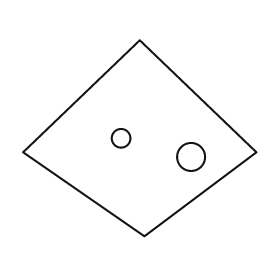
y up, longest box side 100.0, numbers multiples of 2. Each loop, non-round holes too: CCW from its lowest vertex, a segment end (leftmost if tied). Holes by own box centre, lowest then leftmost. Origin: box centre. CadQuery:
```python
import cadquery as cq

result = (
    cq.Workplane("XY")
    .moveTo(2.0, -42.0)
    .lineTo(50.0, -6.0)
    .lineTo(0.0, 42.0)
    .lineTo(-50.0, -6.0)
    .close()
    .moveTo(22.0, -8.0)
    .circle(6.0)
    .moveTo(-8.0, 0.0)
    .circle(4.0)
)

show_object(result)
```